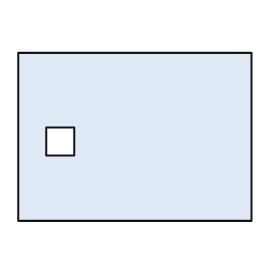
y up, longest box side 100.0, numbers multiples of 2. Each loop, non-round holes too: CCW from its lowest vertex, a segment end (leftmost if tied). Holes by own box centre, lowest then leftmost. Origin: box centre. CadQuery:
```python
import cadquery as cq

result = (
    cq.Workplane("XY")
    .moveTo(-50.0, -36.0)
    .lineTo(50.0, -36.0)
    .lineTo(50.0, 36.0)
    .lineTo(-50.0, 36.0)
    .close()
    .moveTo(-38.0, -8.0)
    .lineTo(-26.0, -8.0)
    .lineTo(-26.0, 4.0)
    .lineTo(-38.0, 4.0)
    .close()
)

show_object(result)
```